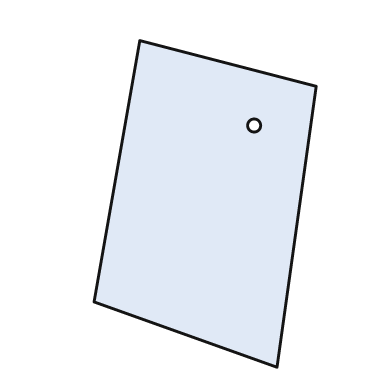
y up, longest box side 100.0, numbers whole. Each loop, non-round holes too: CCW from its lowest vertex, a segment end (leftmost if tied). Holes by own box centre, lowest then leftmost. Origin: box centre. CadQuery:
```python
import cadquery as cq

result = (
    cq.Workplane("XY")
    .moveTo(22.0, -50.0)
    .lineTo(34.0, 36.0)
    .lineTo(-20.0, 50.0)
    .lineTo(-34.0, -30.0)
    .close()
    .moveTo(15.0, 24.0)
    .circle(2.0)
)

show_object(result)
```